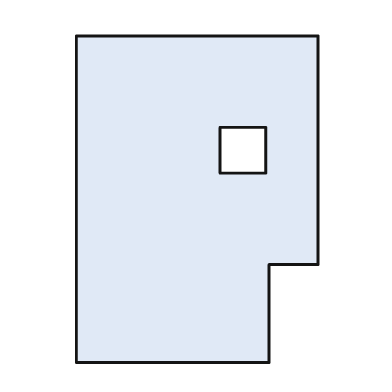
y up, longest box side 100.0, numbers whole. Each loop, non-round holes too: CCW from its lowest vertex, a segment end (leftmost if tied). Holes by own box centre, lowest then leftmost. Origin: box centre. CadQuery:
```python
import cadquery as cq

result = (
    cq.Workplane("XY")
    .moveTo(-37.0, -50.0)
    .lineTo(22.0, -50.0)
    .lineTo(22.0, -20.0)
    .lineTo(37.0, -20.0)
    .lineTo(37.0, 50.0)
    .lineTo(-37.0, 50.0)
    .close()
    .moveTo(7.0, 8.0)
    .lineTo(21.0, 8.0)
    .lineTo(21.0, 22.0)
    .lineTo(7.0, 22.0)
    .close()
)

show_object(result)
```